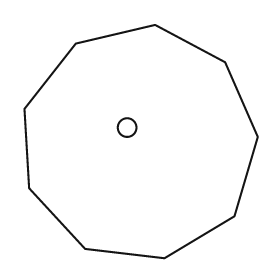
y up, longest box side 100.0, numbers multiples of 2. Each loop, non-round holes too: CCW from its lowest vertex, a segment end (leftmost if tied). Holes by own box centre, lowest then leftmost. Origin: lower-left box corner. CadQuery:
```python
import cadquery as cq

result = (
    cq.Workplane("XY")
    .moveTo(60.0, 0.0)
    .lineTo(90.0, 18.0)
    .lineTo(100.0, 52.0)
    .lineTo(86.0, 84.0)
    .lineTo(56.0, 100.0)
    .lineTo(22.0, 92.0)
    .lineTo(0.0, 64.0)
    .lineTo(2.0, 30.0)
    .lineTo(26.0, 4.0)
    .close()
    .moveTo(44.0, 56.0)
    .circle(4.0)
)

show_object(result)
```